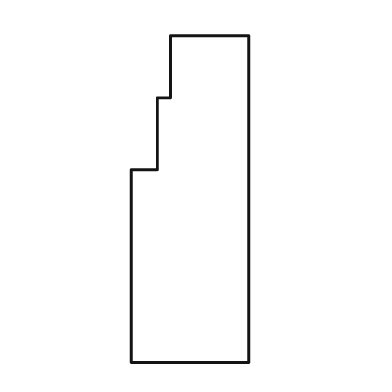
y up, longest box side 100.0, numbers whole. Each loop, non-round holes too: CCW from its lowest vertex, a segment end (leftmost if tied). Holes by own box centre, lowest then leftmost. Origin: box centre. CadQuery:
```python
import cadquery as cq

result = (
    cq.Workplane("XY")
    .moveTo(-18.0, -50.0)
    .lineTo(18.0, -50.0)
    .lineTo(18.0, 50.0)
    .lineTo(-6.0, 50.0)
    .lineTo(-6.0, 31.0)
    .lineTo(-10.0, 31.0)
    .lineTo(-10.0, 9.0)
    .lineTo(-18.0, 9.0)
    .close()
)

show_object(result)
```